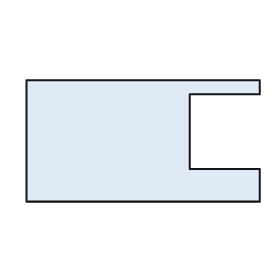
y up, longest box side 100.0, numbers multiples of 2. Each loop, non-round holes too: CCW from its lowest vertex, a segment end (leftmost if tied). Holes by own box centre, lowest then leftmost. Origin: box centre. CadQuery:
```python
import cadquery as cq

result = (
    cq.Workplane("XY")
    .moveTo(-50.0, -26.0)
    .lineTo(50.0, -26.0)
    .lineTo(50.0, -12.0)
    .lineTo(20.0, -12.0)
    .lineTo(20.0, 20.0)
    .lineTo(50.0, 20.0)
    .lineTo(50.0, 26.0)
    .lineTo(-50.0, 26.0)
    .close()
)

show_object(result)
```